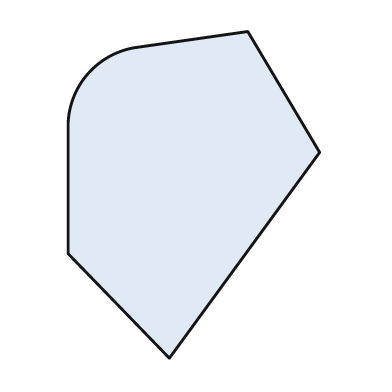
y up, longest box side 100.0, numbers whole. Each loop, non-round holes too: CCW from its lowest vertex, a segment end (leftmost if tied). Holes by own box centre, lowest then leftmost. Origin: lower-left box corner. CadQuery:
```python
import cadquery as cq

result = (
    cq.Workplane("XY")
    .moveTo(31.0, 0.0)
    .lineTo(77.0, 63.0)
    .lineTo(55.0, 100.0)
    .lineTo(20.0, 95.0)
    .threePointArc((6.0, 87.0), (0.0, 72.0))
    .lineTo(0.0, 32.0)
    .close()
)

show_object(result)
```